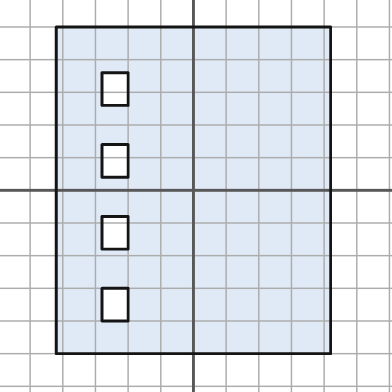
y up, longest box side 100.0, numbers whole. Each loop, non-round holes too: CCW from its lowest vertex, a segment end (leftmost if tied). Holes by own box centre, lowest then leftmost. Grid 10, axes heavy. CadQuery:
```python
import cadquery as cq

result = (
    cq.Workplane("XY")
    .moveTo(-42.0, -50.0)
    .lineTo(42.0, -50.0)
    .lineTo(42.0, 50.0)
    .lineTo(-42.0, 50.0)
    .close()
    .moveTo(-28.0, -40.0)
    .lineTo(-20.0, -40.0)
    .lineTo(-20.0, -30.0)
    .lineTo(-28.0, -30.0)
    .close()
    .moveTo(-28.0, -18.0)
    .lineTo(-20.0, -18.0)
    .lineTo(-20.0, -8.0)
    .lineTo(-28.0, -8.0)
    .close()
    .moveTo(-28.0, 4.0)
    .lineTo(-20.0, 4.0)
    .lineTo(-20.0, 14.0)
    .lineTo(-28.0, 14.0)
    .close()
    .moveTo(-28.0, 26.0)
    .lineTo(-20.0, 26.0)
    .lineTo(-20.0, 36.0)
    .lineTo(-28.0, 36.0)
    .close()
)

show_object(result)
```